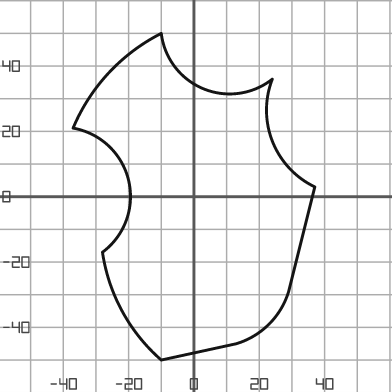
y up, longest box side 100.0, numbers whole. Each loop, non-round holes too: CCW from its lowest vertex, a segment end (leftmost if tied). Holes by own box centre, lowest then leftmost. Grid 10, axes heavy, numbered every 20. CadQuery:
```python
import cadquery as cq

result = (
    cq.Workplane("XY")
    .moveTo(-10.0, -50.0)
    .lineTo(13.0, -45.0)
    .threePointArc((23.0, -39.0), (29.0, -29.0))
    .lineTo(37.0, 3.0)
    .threePointArc((24.0, 17.0), (24.0, 36.0))
    .threePointArc((3.0, 33.0), (-10.0, 50.0))
    .threePointArc((-26.0, 38.0), (-37.0, 21.0))
    .threePointArc((-20.0, 5.0), (-28.0, -17.0))
    .threePointArc((-22.0, -35.0), (-10.0, -50.0))
    .close()
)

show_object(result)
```